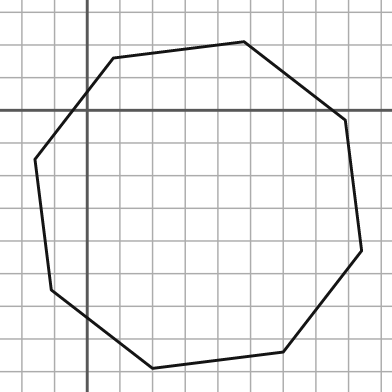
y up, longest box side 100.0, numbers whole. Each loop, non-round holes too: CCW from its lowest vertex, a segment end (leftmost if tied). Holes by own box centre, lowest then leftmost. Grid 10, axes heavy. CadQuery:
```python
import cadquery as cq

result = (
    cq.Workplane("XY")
    .moveTo(20.0, -79.0)
    .lineTo(60.0, -74.0)
    .lineTo(84.0, -43.0)
    .lineTo(79.0, -3.0)
    .lineTo(48.0, 21.0)
    .lineTo(8.0, 16.0)
    .lineTo(-16.0, -15.0)
    .lineTo(-11.0, -55.0)
    .close()
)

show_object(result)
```